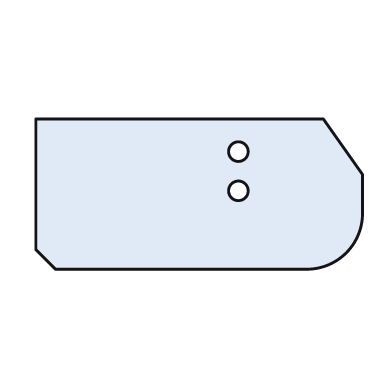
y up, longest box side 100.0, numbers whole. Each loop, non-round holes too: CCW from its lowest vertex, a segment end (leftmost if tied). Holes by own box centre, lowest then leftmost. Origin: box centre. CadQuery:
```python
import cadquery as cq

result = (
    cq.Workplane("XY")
    .moveTo(-44.0, -23.0)
    .lineTo(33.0, -23.0)
    .threePointArc((45.0, -18.0), (50.0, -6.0))
    .lineTo(50.0, 6.0)
    .lineTo(38.0, 23.0)
    .lineTo(-50.0, 23.0)
    .lineTo(-50.0, -17.0)
    .close()
    .moveTo(12.0, 1.0)
    .circle(3.0)
    .moveTo(12.0, 13.0)
    .circle(3.0)
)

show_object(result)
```